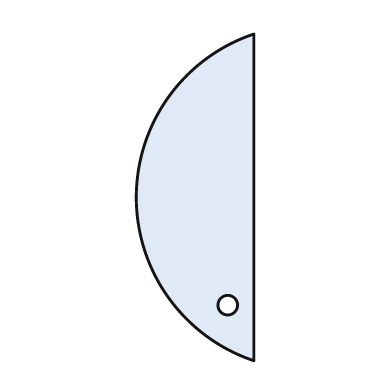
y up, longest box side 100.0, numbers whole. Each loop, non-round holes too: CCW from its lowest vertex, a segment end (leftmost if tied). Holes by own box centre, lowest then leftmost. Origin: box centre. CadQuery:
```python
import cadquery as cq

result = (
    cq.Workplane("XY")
    .moveTo(18.0, -50.0)
    .lineTo(18.0, 50.0)
    .threePointArc((-18.0, 0.0), (18.0, -50.0))
    .close()
    .moveTo(10.0, -33.0)
    .circle(3.0)
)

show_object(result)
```